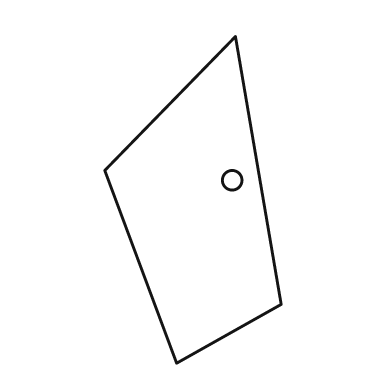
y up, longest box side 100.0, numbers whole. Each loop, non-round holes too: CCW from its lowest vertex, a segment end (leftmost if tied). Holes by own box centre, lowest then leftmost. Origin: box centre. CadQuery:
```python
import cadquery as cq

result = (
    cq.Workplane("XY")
    .moveTo(-5.0, -50.0)
    .lineTo(27.0, -32.0)
    .lineTo(13.0, 50.0)
    .lineTo(-27.0, 9.0)
    .close()
    .moveTo(12.0, 6.0)
    .circle(3.0)
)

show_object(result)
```